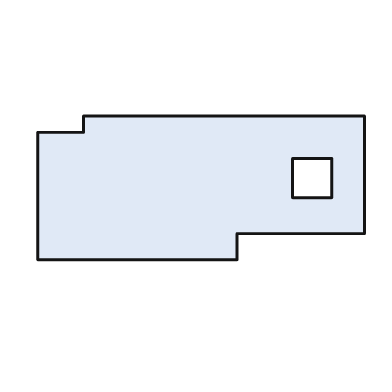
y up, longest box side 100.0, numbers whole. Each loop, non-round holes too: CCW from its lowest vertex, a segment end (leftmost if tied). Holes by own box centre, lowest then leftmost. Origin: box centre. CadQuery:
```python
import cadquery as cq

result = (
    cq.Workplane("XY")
    .moveTo(-50.0, -22.0)
    .lineTo(11.0, -22.0)
    .lineTo(11.0, -14.0)
    .lineTo(50.0, -14.0)
    .lineTo(50.0, 22.0)
    .lineTo(-36.0, 22.0)
    .lineTo(-36.0, 17.0)
    .lineTo(-50.0, 17.0)
    .close()
    .moveTo(28.0, -3.0)
    .lineTo(40.0, -3.0)
    .lineTo(40.0, 9.0)
    .lineTo(28.0, 9.0)
    .close()
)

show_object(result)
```